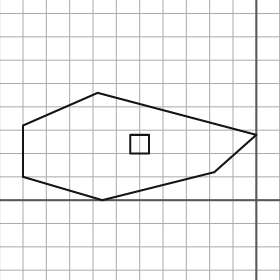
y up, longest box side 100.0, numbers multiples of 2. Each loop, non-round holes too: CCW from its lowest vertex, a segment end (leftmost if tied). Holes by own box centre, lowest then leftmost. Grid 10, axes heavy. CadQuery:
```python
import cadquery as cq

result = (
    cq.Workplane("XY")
    .moveTo(-66.0, 0.0)
    .lineTo(-18.0, 12.0)
    .lineTo(0.0, 28.0)
    .lineTo(-68.0, 46.0)
    .lineTo(-100.0, 32.0)
    .lineTo(-100.0, 10.0)
    .close()
    .moveTo(-54.0, 20.0)
    .lineTo(-46.0, 20.0)
    .lineTo(-46.0, 28.0)
    .lineTo(-54.0, 28.0)
    .close()
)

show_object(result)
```